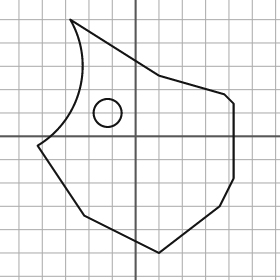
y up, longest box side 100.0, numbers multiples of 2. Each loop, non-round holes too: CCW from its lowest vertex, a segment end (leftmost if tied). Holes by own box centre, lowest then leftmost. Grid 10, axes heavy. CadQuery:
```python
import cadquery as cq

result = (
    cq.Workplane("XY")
    .moveTo(10.0, -50.0)
    .lineTo(36.0, -30.0)
    .lineTo(42.0, -18.0)
    .lineTo(42.0, 14.0)
    .lineTo(38.0, 18.0)
    .lineTo(10.0, 26.0)
    .lineTo(-28.0, 50.0)
    .threePointArc((-24.0, 20.0), (-42.0, -4.0))
    .lineTo(-22.0, -34.0)
    .close()
    .moveTo(-12.0, 10.0)
    .circle(6.0)
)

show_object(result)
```